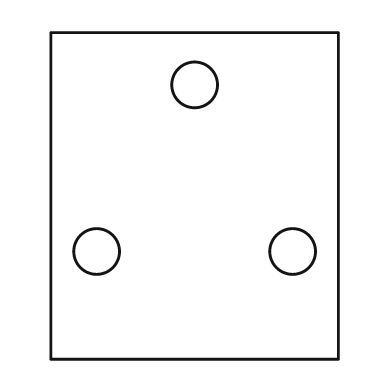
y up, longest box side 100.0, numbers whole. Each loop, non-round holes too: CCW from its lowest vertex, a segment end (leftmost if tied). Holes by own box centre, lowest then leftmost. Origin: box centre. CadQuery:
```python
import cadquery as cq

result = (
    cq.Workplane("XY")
    .moveTo(-44.0, -50.0)
    .lineTo(44.0, -50.0)
    .lineTo(44.0, 50.0)
    .lineTo(-44.0, 50.0)
    .close()
    .moveTo(-30.0, -17.0)
    .circle(7.0)
    .moveTo(30.0, -17.0)
    .circle(7.0)
    .moveTo(0.0, 34.0)
    .circle(7.0)
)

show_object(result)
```